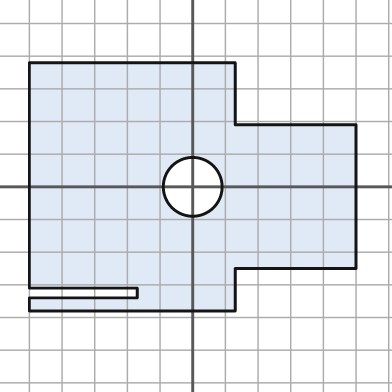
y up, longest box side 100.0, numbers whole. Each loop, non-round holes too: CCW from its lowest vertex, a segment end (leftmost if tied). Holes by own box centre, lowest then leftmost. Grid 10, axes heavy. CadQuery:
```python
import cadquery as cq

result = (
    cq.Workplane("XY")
    .moveTo(-50.0, -38.0)
    .lineTo(13.0, -38.0)
    .lineTo(13.0, -25.0)
    .lineTo(50.0, -25.0)
    .lineTo(50.0, 19.0)
    .lineTo(13.0, 19.0)
    .lineTo(13.0, 38.0)
    .lineTo(-50.0, 38.0)
    .lineTo(-50.0, -31.0)
    .lineTo(-17.0, -31.0)
    .lineTo(-17.0, -34.0)
    .lineTo(-50.0, -34.0)
    .close()
    .moveTo(0.0, 0.0)
    .circle(9.0)
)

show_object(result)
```